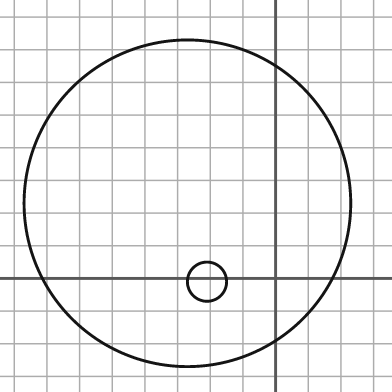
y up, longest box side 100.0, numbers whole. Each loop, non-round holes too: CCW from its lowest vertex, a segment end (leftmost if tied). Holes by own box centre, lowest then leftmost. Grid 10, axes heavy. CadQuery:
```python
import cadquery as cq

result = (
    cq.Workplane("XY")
    .moveTo(-27.0, 23.0)
    .circle(50.0)
    .moveTo(-21.0, -1.0)
    .circle(6.0)
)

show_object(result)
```